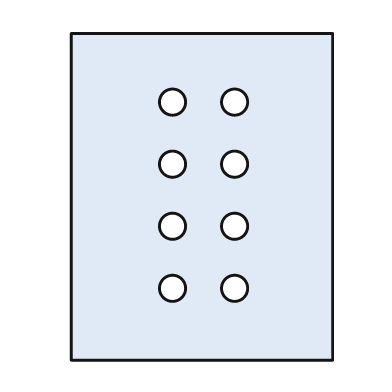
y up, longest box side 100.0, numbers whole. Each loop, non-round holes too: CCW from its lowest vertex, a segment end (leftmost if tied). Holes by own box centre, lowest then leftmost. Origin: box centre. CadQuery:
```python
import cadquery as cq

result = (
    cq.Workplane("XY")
    .moveTo(-40.0, -50.0)
    .lineTo(40.0, -50.0)
    .lineTo(40.0, 50.0)
    .lineTo(-40.0, 50.0)
    .close()
    .moveTo(-9.0, -28.0)
    .circle(4.0)
    .moveTo(10.0, -28.0)
    .circle(4.0)
    .moveTo(-9.0, -9.0)
    .circle(4.0)
    .moveTo(10.0, -9.0)
    .circle(4.0)
    .moveTo(-9.0, 10.0)
    .circle(4.0)
    .moveTo(10.0, 10.0)
    .circle(4.0)
    .moveTo(-9.0, 29.0)
    .circle(4.0)
    .moveTo(10.0, 29.0)
    .circle(4.0)
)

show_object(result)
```